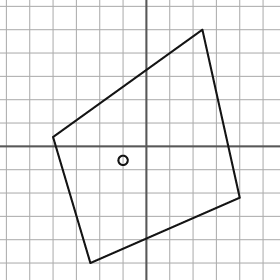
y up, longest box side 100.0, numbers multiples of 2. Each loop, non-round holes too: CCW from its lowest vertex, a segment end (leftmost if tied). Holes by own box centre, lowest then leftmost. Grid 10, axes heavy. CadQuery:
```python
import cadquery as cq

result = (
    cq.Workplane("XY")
    .moveTo(-24.0, -50.0)
    .lineTo(40.0, -22.0)
    .lineTo(24.0, 50.0)
    .lineTo(-40.0, 4.0)
    .close()
    .moveTo(-10.0, -6.0)
    .circle(2.0)
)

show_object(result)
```